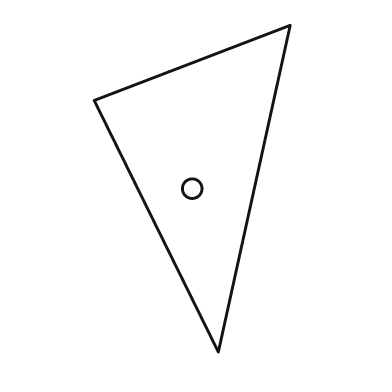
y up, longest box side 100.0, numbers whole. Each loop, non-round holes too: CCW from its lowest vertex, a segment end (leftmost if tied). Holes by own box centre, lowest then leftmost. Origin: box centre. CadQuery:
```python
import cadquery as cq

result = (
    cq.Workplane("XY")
    .moveTo(8.0, -50.0)
    .lineTo(30.0, 50.0)
    .lineTo(-30.0, 27.0)
    .close()
    .moveTo(0.0, 0.0)
    .circle(3.0)
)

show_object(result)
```